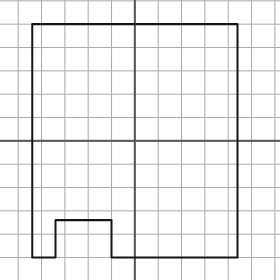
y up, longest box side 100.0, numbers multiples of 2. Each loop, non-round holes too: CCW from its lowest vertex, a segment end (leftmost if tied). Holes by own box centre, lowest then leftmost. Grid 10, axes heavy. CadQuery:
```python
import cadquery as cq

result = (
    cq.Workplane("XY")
    .moveTo(-44.0, -50.0)
    .lineTo(-34.0, -50.0)
    .lineTo(-34.0, -34.0)
    .lineTo(-10.0, -34.0)
    .lineTo(-10.0, -50.0)
    .lineTo(44.0, -50.0)
    .lineTo(44.0, 50.0)
    .lineTo(-44.0, 50.0)
    .close()
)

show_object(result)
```